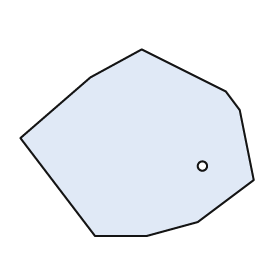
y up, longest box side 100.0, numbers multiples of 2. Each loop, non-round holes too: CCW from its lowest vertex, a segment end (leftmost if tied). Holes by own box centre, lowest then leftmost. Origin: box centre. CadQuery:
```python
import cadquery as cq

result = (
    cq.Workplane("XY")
    .moveTo(-18.0, -40.0)
    .lineTo(4.0, -40.0)
    .lineTo(26.0, -34.0)
    .lineTo(50.0, -16.0)
    .lineTo(44.0, 14.0)
    .lineTo(38.0, 22.0)
    .lineTo(2.0, 40.0)
    .lineTo(-20.0, 28.0)
    .lineTo(-50.0, 2.0)
    .close()
    .moveTo(28.0, -10.0)
    .circle(2.0)
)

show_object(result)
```